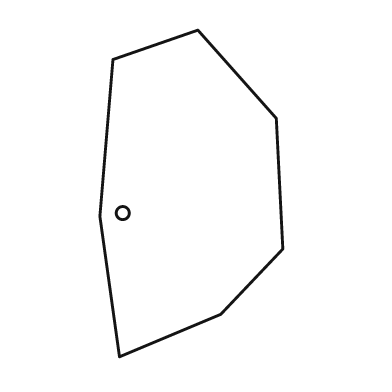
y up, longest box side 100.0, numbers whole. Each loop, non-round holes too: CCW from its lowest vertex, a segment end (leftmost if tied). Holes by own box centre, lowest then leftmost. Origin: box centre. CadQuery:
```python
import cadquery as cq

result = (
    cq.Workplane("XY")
    .moveTo(-22.0, -50.0)
    .lineTo(9.0, -37.0)
    .lineTo(28.0, -17.0)
    .lineTo(26.0, 23.0)
    .lineTo(2.0, 50.0)
    .lineTo(-24.0, 41.0)
    .lineTo(-28.0, -7.0)
    .close()
    .moveTo(-21.0, -6.0)
    .circle(2.0)
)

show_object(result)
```